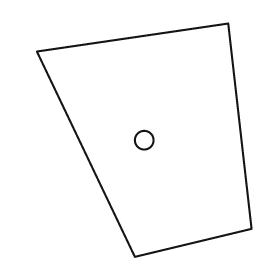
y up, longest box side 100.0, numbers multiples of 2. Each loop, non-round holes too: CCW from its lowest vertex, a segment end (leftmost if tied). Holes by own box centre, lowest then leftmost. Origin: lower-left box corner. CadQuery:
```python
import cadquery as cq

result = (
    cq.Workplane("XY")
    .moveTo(42.0, 0.0)
    .lineTo(92.0, 12.0)
    .lineTo(82.0, 100.0)
    .lineTo(0.0, 88.0)
    .close()
    .moveTo(46.0, 50.0)
    .circle(4.0)
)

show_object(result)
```